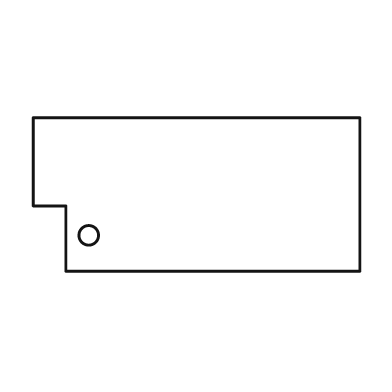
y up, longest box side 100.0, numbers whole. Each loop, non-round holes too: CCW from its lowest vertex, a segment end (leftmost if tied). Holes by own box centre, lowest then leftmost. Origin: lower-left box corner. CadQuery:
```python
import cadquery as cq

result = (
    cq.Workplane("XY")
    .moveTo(10.0, 0.0)
    .lineTo(100.0, 0.0)
    .lineTo(100.0, 47.0)
    .lineTo(0.0, 47.0)
    .lineTo(0.0, 20.0)
    .lineTo(10.0, 20.0)
    .close()
    .moveTo(17.0, 11.0)
    .circle(3.0)
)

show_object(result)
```